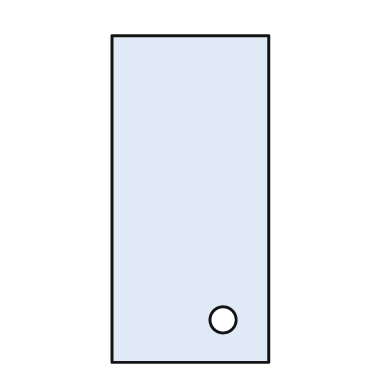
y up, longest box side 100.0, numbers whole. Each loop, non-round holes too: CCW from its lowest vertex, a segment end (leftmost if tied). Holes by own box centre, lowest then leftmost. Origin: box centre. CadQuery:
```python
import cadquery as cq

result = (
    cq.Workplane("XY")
    .moveTo(-24.0, -50.0)
    .lineTo(24.0, -50.0)
    .lineTo(24.0, 50.0)
    .lineTo(-24.0, 50.0)
    .close()
    .moveTo(10.0, -37.0)
    .circle(4.0)
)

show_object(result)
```